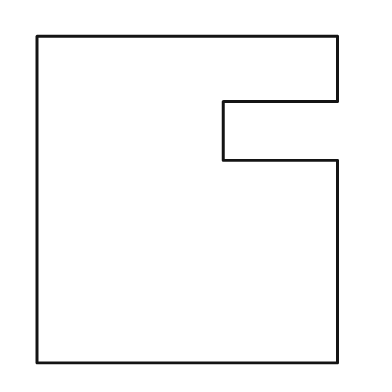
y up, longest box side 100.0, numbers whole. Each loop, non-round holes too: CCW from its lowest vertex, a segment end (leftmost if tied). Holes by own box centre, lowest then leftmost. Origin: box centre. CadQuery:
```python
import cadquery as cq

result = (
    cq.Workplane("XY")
    .moveTo(-46.0, -50.0)
    .lineTo(46.0, -50.0)
    .lineTo(46.0, 12.0)
    .lineTo(11.0, 12.0)
    .lineTo(11.0, 30.0)
    .lineTo(46.0, 30.0)
    .lineTo(46.0, 50.0)
    .lineTo(-46.0, 50.0)
    .close()
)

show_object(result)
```